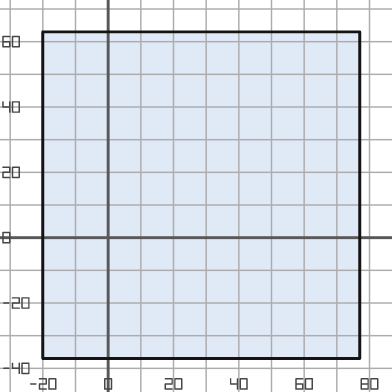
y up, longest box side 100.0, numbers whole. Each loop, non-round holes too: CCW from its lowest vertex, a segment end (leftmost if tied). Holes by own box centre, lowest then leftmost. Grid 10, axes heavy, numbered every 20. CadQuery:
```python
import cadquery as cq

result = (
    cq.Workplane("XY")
    .moveTo(-20.0, -37.0)
    .lineTo(77.0, -37.0)
    .lineTo(77.0, 63.0)
    .lineTo(-20.0, 63.0)
    .close()
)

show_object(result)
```